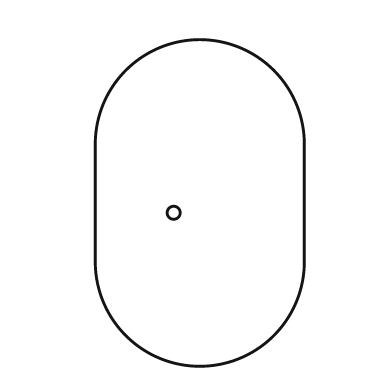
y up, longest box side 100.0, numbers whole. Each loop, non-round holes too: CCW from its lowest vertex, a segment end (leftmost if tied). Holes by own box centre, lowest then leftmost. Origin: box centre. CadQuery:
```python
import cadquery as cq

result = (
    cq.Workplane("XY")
    .moveTo(-32.0, -18.0)
    .threePointArc((0.0, -50.0), (32.0, -18.0))
    .lineTo(32.0, 18.0)
    .threePointArc((0.0, 50.0), (-32.0, 18.0))
    .close()
    .moveTo(-8.0, -3.0)
    .circle(2.0)
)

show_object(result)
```